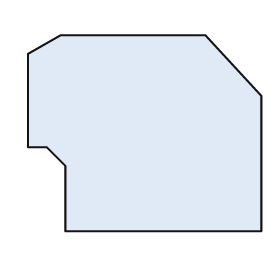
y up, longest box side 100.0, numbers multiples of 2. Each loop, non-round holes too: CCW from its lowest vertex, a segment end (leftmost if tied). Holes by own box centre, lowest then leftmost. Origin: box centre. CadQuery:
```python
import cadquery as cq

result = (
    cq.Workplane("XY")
    .moveTo(-34.0, -42.0)
    .lineTo(50.0, -42.0)
    .lineTo(50.0, 16.0)
    .lineTo(26.0, 42.0)
    .lineTo(-36.0, 42.0)
    .lineTo(-50.0, 34.0)
    .lineTo(-50.0, -6.0)
    .lineTo(-42.0, -6.0)
    .lineTo(-34.0, -14.0)
    .close()
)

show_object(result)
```